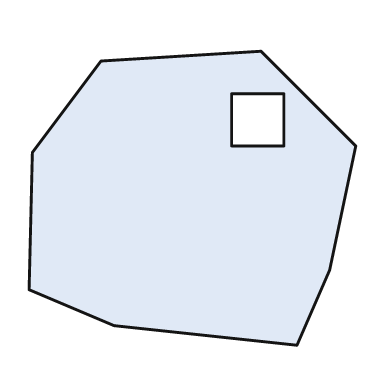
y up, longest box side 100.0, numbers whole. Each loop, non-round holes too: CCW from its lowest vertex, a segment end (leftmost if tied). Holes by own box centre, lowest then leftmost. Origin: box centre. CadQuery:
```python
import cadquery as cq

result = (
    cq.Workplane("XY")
    .moveTo(32.0, -45.0)
    .lineTo(42.0, -22.0)
    .lineTo(50.0, 16.0)
    .lineTo(21.0, 45.0)
    .lineTo(-28.0, 42.0)
    .lineTo(-49.0, 14.0)
    .lineTo(-50.0, -28.0)
    .lineTo(-24.0, -39.0)
    .close()
    .moveTo(12.0, 16.0)
    .lineTo(28.0, 16.0)
    .lineTo(28.0, 32.0)
    .lineTo(12.0, 32.0)
    .close()
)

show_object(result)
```